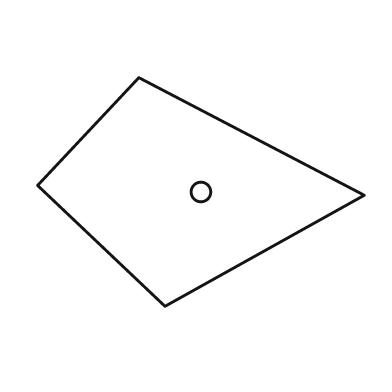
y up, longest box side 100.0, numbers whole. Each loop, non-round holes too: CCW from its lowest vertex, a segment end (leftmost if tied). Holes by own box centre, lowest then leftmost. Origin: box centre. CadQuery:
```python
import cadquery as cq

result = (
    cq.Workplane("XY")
    .moveTo(-11.0, -35.0)
    .lineTo(50.0, -1.0)
    .lineTo(-19.0, 35.0)
    .lineTo(-50.0, 2.0)
    .close()
    .moveTo(0.0, 0.0)
    .circle(3.0)
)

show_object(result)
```